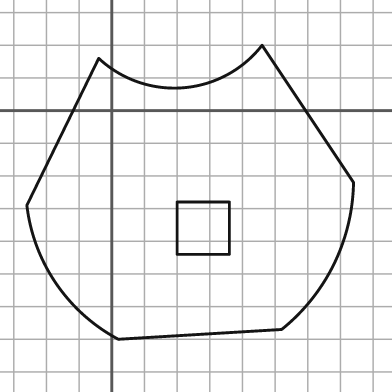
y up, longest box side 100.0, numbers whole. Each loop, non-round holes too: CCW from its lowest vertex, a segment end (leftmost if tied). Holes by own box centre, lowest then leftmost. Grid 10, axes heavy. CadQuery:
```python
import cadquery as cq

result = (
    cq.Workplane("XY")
    .moveTo(2.0, -70.0)
    .lineTo(52.0, -67.0)
    .threePointArc((68.0, -47.0), (74.0, -22.0))
    .lineTo(46.0, 20.0)
    .threePointArc((22.0, 7.0), (-4.0, 16.0))
    .lineTo(-26.0, -29.0)
    .threePointArc((-17.0, -53.0), (2.0, -70.0))
    .close()
    .moveTo(20.0, -44.0)
    .lineTo(36.0, -44.0)
    .lineTo(36.0, -28.0)
    .lineTo(20.0, -28.0)
    .close()
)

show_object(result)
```